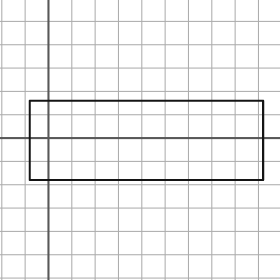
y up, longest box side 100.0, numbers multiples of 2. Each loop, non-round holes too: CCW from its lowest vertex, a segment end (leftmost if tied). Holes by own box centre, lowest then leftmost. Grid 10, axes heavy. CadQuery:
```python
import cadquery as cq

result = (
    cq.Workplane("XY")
    .moveTo(-8.0, -18.0)
    .lineTo(92.0, -18.0)
    .lineTo(92.0, 16.0)
    .lineTo(-8.0, 16.0)
    .close()
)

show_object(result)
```